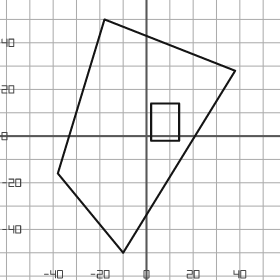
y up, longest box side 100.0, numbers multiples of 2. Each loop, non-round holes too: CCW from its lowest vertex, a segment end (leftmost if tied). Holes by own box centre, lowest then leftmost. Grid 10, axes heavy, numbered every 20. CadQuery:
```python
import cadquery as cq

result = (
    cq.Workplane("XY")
    .moveTo(-10.0, -50.0)
    .lineTo(38.0, 28.0)
    .lineTo(-18.0, 50.0)
    .lineTo(-38.0, -16.0)
    .close()
    .moveTo(2.0, -2.0)
    .lineTo(14.0, -2.0)
    .lineTo(14.0, 14.0)
    .lineTo(2.0, 14.0)
    .close()
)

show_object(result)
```